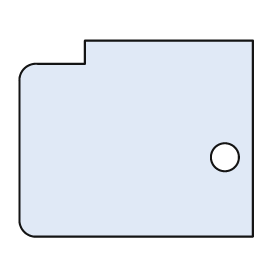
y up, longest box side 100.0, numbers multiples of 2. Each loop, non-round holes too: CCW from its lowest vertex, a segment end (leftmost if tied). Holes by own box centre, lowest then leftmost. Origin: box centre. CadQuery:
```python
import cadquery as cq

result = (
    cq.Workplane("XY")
    .moveTo(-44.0, -42.0)
    .lineTo(50.0, -42.0)
    .lineTo(50.0, 42.0)
    .lineTo(-22.0, 42.0)
    .lineTo(-22.0, 32.0)
    .lineTo(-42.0, 32.0)
    .threePointArc((-48.0, 30.0), (-50.0, 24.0))
    .lineTo(-50.0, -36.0)
    .threePointArc((-48.0, -40.0), (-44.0, -42.0))
    .close()
    .moveTo(38.0, -8.0)
    .circle(6.0)
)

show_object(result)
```